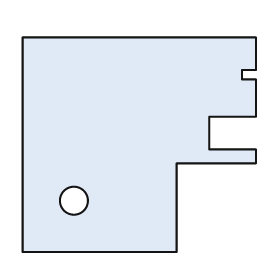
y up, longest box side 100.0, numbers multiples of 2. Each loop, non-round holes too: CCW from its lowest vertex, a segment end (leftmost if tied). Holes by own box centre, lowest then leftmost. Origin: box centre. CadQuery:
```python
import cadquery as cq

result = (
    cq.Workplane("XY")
    .moveTo(-50.0, -46.0)
    .lineTo(16.0, -46.0)
    .lineTo(16.0, -8.0)
    .lineTo(50.0, -8.0)
    .lineTo(50.0, -2.0)
    .lineTo(30.0, -2.0)
    .lineTo(30.0, 12.0)
    .lineTo(50.0, 12.0)
    .lineTo(50.0, 28.0)
    .lineTo(44.0, 28.0)
    .lineTo(44.0, 32.0)
    .lineTo(50.0, 32.0)
    .lineTo(50.0, 46.0)
    .lineTo(-50.0, 46.0)
    .close()
    .moveTo(-28.0, -24.0)
    .circle(6.0)
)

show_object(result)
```